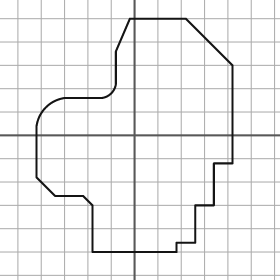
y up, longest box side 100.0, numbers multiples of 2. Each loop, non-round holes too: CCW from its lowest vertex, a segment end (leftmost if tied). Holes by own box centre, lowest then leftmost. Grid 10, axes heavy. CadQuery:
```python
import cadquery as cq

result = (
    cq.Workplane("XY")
    .moveTo(-18.0, -50.0)
    .lineTo(18.0, -50.0)
    .lineTo(18.0, -46.0)
    .lineTo(26.0, -46.0)
    .lineTo(26.0, -30.0)
    .lineTo(34.0, -30.0)
    .lineTo(34.0, -12.0)
    .lineTo(42.0, -12.0)
    .lineTo(42.0, 30.0)
    .lineTo(22.0, 50.0)
    .lineTo(-2.0, 50.0)
    .lineTo(-8.0, 36.0)
    .lineTo(-8.0, 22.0)
    .threePointArc((-10.0, 18.0), (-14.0, 16.0))
    .lineTo(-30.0, 16.0)
    .threePointArc((-38.0, 12.0), (-42.0, 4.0))
    .lineTo(-42.0, -18.0)
    .lineTo(-34.0, -26.0)
    .lineTo(-22.0, -26.0)
    .lineTo(-18.0, -30.0)
    .close()
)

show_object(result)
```